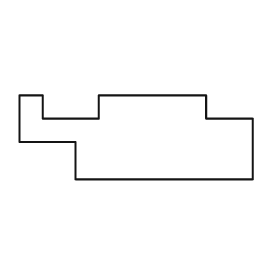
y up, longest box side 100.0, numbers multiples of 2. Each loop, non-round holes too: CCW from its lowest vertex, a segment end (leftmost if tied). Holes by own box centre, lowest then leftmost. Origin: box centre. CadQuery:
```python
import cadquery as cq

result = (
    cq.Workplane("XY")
    .moveTo(-26.0, -18.0)
    .lineTo(50.0, -18.0)
    .lineTo(50.0, 8.0)
    .lineTo(30.0, 8.0)
    .lineTo(30.0, 18.0)
    .lineTo(-16.0, 18.0)
    .lineTo(-16.0, 8.0)
    .lineTo(-40.0, 8.0)
    .lineTo(-40.0, 18.0)
    .lineTo(-50.0, 18.0)
    .lineTo(-50.0, -2.0)
    .lineTo(-26.0, -2.0)
    .close()
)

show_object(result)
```